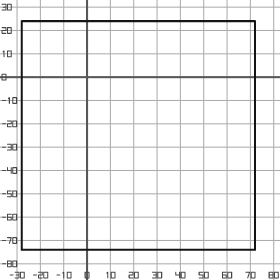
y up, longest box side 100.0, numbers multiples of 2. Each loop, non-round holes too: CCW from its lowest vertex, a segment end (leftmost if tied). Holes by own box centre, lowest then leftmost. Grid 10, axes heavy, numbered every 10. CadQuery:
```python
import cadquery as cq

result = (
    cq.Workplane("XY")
    .moveTo(-28.0, -74.0)
    .lineTo(72.0, -74.0)
    .lineTo(72.0, 24.0)
    .lineTo(-28.0, 24.0)
    .close()
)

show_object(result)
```